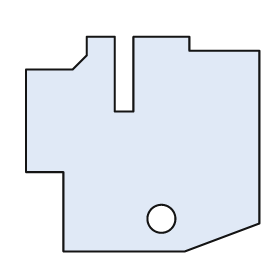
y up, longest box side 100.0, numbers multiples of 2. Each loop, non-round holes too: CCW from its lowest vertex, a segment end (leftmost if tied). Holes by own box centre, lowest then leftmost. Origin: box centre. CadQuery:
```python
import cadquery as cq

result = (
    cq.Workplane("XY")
    .moveTo(-34.0, -46.0)
    .lineTo(18.0, -46.0)
    .lineTo(50.0, -34.0)
    .lineTo(50.0, 40.0)
    .lineTo(20.0, 40.0)
    .lineTo(20.0, 46.0)
    .lineTo(-4.0, 46.0)
    .lineTo(-4.0, 14.0)
    .lineTo(-12.0, 14.0)
    .lineTo(-12.0, 46.0)
    .lineTo(-24.0, 46.0)
    .lineTo(-24.0, 38.0)
    .lineTo(-30.0, 32.0)
    .lineTo(-50.0, 32.0)
    .lineTo(-50.0, -12.0)
    .lineTo(-34.0, -12.0)
    .close()
    .moveTo(8.0, -32.0)
    .circle(6.0)
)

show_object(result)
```